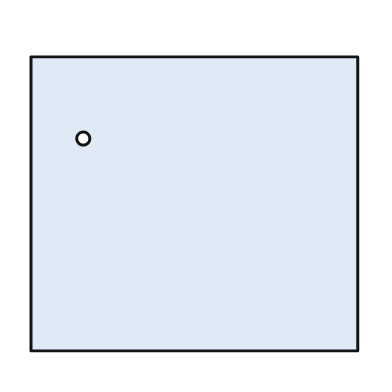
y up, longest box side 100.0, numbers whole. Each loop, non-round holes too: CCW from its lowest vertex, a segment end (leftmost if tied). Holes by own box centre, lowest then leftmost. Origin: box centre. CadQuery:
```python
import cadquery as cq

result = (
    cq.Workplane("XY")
    .moveTo(-50.0, -45.0)
    .lineTo(50.0, -45.0)
    .lineTo(50.0, 45.0)
    .lineTo(-50.0, 45.0)
    .close()
    .moveTo(-34.0, 20.0)
    .circle(2.0)
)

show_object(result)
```